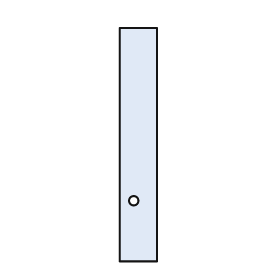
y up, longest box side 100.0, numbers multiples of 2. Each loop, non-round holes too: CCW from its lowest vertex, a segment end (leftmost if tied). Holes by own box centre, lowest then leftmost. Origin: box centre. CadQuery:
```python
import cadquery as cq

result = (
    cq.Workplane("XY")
    .moveTo(-8.0, -50.0)
    .lineTo(8.0, -50.0)
    .lineTo(8.0, 50.0)
    .lineTo(-8.0, 50.0)
    .close()
    .moveTo(-2.0, -24.0)
    .circle(2.0)
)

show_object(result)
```